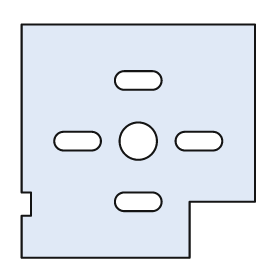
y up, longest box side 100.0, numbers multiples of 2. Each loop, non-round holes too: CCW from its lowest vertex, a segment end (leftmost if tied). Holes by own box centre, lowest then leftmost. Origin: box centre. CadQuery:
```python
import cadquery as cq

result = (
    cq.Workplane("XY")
    .moveTo(-50.0, -50.0)
    .lineTo(22.0, -50.0)
    .lineTo(22.0, -26.0)
    .lineTo(50.0, -26.0)
    .lineTo(50.0, 50.0)
    .lineTo(-50.0, 50.0)
    .lineTo(-50.0, -22.0)
    .lineTo(-46.0, -22.0)
    .lineTo(-46.0, -32.0)
    .lineTo(-50.0, -32.0)
    .close()
    .moveTo(-6.0, -30.0)
    .lineTo(6.0, -30.0)
    .threePointArc((10.0, -26.0), (6.0, -22.0))
    .lineTo(-6.0, -22.0)
    .threePointArc((-10.0, -26.0), (-6.0, -30.0))
    .close()
    .moveTo(-32.0, -4.0)
    .lineTo(-20.0, -4.0)
    .threePointArc((-16.0, 0.0), (-20.0, 4.0))
    .lineTo(-32.0, 4.0)
    .threePointArc((-36.0, 0.0), (-32.0, -4.0))
    .close()
    .moveTo(0.0, 0.0)
    .circle(8.0)
    .moveTo(20.0, -4.0)
    .lineTo(32.0, -4.0)
    .threePointArc((36.0, 0.0), (32.0, 4.0))
    .lineTo(20.0, 4.0)
    .threePointArc((16.0, 0.0), (20.0, -4.0))
    .close()
    .moveTo(-6.0, 22.0)
    .lineTo(6.0, 22.0)
    .threePointArc((10.0, 26.0), (6.0, 30.0))
    .lineTo(-6.0, 30.0)
    .threePointArc((-10.0, 26.0), (-6.0, 22.0))
    .close()
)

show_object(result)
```